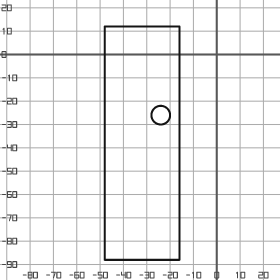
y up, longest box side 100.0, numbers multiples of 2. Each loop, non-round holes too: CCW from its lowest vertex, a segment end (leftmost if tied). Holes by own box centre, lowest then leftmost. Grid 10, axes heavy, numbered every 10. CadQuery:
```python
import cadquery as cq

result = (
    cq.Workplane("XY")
    .moveTo(-48.0, -88.0)
    .lineTo(-16.0, -88.0)
    .lineTo(-16.0, 12.0)
    .lineTo(-48.0, 12.0)
    .close()
    .moveTo(-24.0, -26.0)
    .circle(4.0)
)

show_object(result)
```